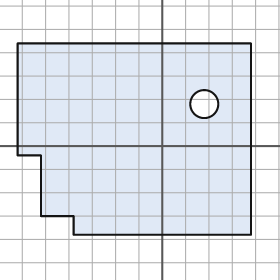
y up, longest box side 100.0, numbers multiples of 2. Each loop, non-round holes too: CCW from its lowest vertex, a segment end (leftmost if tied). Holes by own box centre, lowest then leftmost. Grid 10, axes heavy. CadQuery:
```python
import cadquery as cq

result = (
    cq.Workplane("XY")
    .moveTo(-38.0, -38.0)
    .lineTo(38.0, -38.0)
    .lineTo(38.0, 44.0)
    .lineTo(-62.0, 44.0)
    .lineTo(-62.0, -4.0)
    .lineTo(-52.0, -4.0)
    .lineTo(-52.0, -30.0)
    .lineTo(-38.0, -30.0)
    .close()
    .moveTo(18.0, 18.0)
    .circle(6.0)
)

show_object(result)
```